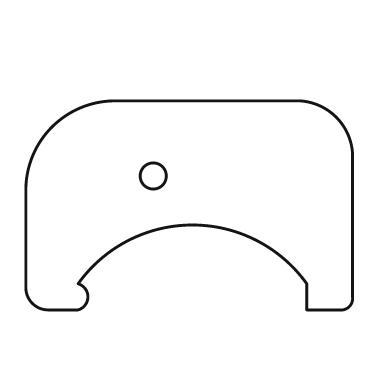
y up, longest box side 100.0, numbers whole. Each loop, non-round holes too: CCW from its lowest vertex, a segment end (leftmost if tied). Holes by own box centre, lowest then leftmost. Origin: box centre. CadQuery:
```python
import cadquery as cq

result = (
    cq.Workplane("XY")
    .moveTo(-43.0, -32.0)
    .lineTo(-34.0, -32.0)
    .threePointArc((-31.0, -28.0), (-34.0, -24.0))
    .threePointArc((1.0, -6.0), (36.0, -24.0))
    .lineTo(36.0, -32.0)
    .lineTo(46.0, -32.0)
    .threePointArc((49.0, -31.0), (50.0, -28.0))
    .lineTo(50.0, 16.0)
    .threePointArc((45.0, 27.0), (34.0, 32.0))
    .lineTo(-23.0, 32.0)
    .threePointArc((-42.0, 24.0), (-50.0, 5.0))
    .lineTo(-50.0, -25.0)
    .threePointArc((-48.0, -30.0), (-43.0, -32.0))
    .close()
    .moveTo(-11.0, 9.0)
    .circle(4.0)
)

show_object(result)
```